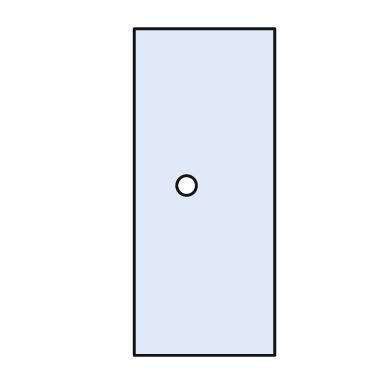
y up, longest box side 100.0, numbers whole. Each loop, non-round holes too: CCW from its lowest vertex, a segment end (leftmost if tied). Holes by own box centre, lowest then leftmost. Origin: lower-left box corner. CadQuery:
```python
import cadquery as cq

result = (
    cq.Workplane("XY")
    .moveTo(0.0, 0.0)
    .lineTo(43.0, 0.0)
    .lineTo(43.0, 100.0)
    .lineTo(0.0, 100.0)
    .close()
    .moveTo(16.0, 52.0)
    .circle(3.0)
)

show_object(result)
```